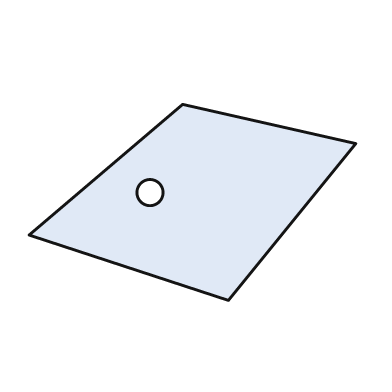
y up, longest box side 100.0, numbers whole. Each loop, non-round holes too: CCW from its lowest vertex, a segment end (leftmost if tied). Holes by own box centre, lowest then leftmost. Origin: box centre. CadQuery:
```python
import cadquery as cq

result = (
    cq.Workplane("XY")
    .moveTo(11.0, -30.0)
    .lineTo(50.0, 18.0)
    .lineTo(-3.0, 30.0)
    .lineTo(-50.0, -10.0)
    .close()
    .moveTo(-13.0, 3.0)
    .circle(4.0)
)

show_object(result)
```